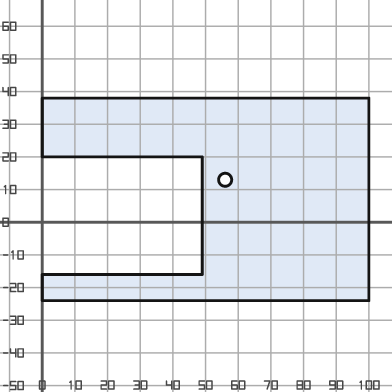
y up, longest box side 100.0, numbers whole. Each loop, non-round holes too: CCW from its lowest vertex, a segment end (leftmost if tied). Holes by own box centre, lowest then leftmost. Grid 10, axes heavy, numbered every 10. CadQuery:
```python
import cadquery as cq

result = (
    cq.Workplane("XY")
    .moveTo(0.0, -24.0)
    .lineTo(100.0, -24.0)
    .lineTo(100.0, 38.0)
    .lineTo(0.0, 38.0)
    .lineTo(0.0, 20.0)
    .lineTo(49.0, 20.0)
    .lineTo(49.0, -16.0)
    .lineTo(0.0, -16.0)
    .close()
    .moveTo(56.0, 13.0)
    .circle(2.0)
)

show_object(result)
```